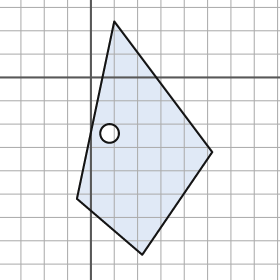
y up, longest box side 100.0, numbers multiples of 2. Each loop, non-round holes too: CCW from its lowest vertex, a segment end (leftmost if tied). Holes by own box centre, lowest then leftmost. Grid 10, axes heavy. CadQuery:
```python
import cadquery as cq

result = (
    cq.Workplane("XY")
    .moveTo(22.0, -76.0)
    .lineTo(52.0, -32.0)
    .lineTo(10.0, 24.0)
    .lineTo(-6.0, -52.0)
    .close()
    .moveTo(8.0, -24.0)
    .circle(4.0)
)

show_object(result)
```